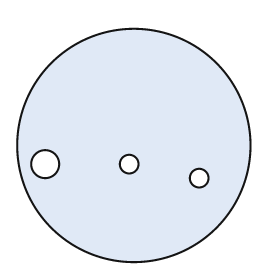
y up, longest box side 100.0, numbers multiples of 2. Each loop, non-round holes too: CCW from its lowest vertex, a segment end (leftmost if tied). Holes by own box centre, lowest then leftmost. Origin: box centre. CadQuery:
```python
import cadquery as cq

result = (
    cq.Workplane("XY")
    .moveTo(0.0, 0.0)
    .circle(50.0)
    .moveTo(28.0, -14.0)
    .circle(4.0)
    .moveTo(-38.0, -8.0)
    .circle(6.0)
    .moveTo(-2.0, -8.0)
    .circle(4.0)
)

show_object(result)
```